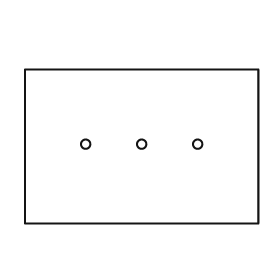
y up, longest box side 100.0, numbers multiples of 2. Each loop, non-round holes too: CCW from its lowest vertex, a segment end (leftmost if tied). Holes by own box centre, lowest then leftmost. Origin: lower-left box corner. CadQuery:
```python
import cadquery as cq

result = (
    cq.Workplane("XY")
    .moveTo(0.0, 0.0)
    .lineTo(100.0, 0.0)
    .lineTo(100.0, 66.0)
    .lineTo(0.0, 66.0)
    .close()
    .moveTo(26.0, 34.0)
    .circle(2.0)
    .moveTo(50.0, 34.0)
    .circle(2.0)
    .moveTo(74.0, 34.0)
    .circle(2.0)
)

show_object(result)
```